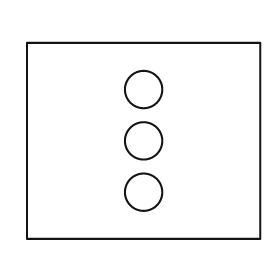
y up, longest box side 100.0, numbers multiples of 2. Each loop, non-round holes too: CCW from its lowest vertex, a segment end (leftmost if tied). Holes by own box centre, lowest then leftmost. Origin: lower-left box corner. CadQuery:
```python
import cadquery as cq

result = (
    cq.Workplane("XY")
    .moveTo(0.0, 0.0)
    .lineTo(100.0, 0.0)
    .lineTo(100.0, 84.0)
    .lineTo(0.0, 84.0)
    .close()
    .moveTo(50.0, 20.0)
    .circle(8.0)
    .moveTo(50.0, 42.0)
    .circle(8.0)
    .moveTo(50.0, 64.0)
    .circle(8.0)
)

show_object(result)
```